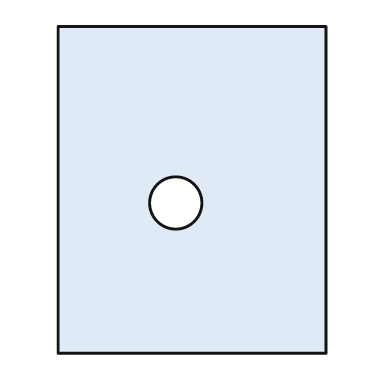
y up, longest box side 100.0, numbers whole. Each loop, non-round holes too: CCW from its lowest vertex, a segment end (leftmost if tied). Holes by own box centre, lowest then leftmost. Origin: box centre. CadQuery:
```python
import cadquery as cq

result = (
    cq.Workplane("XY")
    .moveTo(-41.0, -50.0)
    .lineTo(41.0, -50.0)
    .lineTo(41.0, 50.0)
    .lineTo(-41.0, 50.0)
    .close()
    .moveTo(-5.0, -4.0)
    .circle(8.0)
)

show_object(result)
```